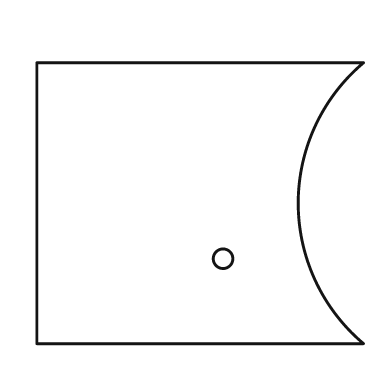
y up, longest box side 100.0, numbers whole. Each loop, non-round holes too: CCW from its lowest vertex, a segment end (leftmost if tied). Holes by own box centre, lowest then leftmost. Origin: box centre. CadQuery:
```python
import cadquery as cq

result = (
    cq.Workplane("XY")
    .moveTo(-50.0, -43.0)
    .lineTo(50.0, -43.0)
    .threePointArc((30.0, 0.0), (50.0, 43.0))
    .lineTo(-50.0, 43.0)
    .close()
    .moveTo(7.0, -17.0)
    .circle(3.0)
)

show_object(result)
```